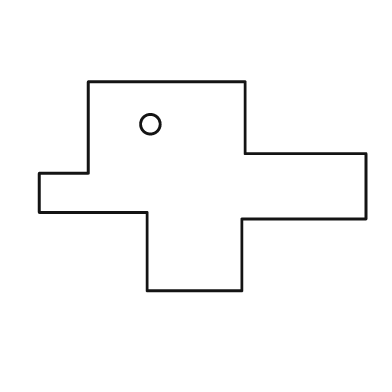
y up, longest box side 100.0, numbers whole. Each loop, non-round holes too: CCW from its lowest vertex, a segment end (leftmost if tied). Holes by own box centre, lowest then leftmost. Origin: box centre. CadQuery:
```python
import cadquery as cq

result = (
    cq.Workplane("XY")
    .moveTo(-17.0, -32.0)
    .lineTo(12.0, -32.0)
    .lineTo(12.0, -10.0)
    .lineTo(50.0, -10.0)
    .lineTo(50.0, 10.0)
    .lineTo(13.0, 10.0)
    .lineTo(13.0, 32.0)
    .lineTo(-35.0, 32.0)
    .lineTo(-35.0, 4.0)
    .lineTo(-50.0, 4.0)
    .lineTo(-50.0, -8.0)
    .lineTo(-17.0, -8.0)
    .close()
    .moveTo(-16.0, 19.0)
    .circle(3.0)
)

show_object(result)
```